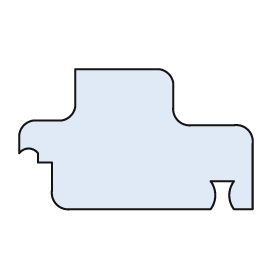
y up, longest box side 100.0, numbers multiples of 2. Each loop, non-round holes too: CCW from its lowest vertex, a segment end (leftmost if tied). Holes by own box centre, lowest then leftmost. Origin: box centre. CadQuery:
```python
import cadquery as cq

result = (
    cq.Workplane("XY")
    .moveTo(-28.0, -30.0)
    .lineTo(32.0, -30.0)
    .threePointArc((34.0, -24.0), (32.0, -18.0))
    .lineTo(42.0, -18.0)
    .threePointArc((40.0, -24.0), (42.0, -30.0))
    .lineTo(50.0, -30.0)
    .lineTo(50.0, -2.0)
    .threePointArc((48.0, 4.0), (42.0, 6.0))
    .lineTo(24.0, 6.0)
    .threePointArc((18.0, 8.0), (16.0, 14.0))
    .lineTo(16.0, 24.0)
    .threePointArc((14.0, 28.0), (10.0, 30.0))
    .lineTo(-26.0, 30.0)
    .lineTo(-26.0, 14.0)
    .threePointArc((-28.0, 10.0), (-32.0, 8.0))
    .lineTo(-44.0, 8.0)
    .threePointArc((-48.0, 6.0), (-50.0, 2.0))
    .lineTo(-50.0, -6.0)
    .threePointArc((-46.0, -4.0), (-42.0, -6.0))
    .lineTo(-42.0, -10.0)
    .lineTo(-36.0, -10.0)
    .lineTo(-36.0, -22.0)
    .threePointArc((-34.0, -28.0), (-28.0, -30.0))
    .close()
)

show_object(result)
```